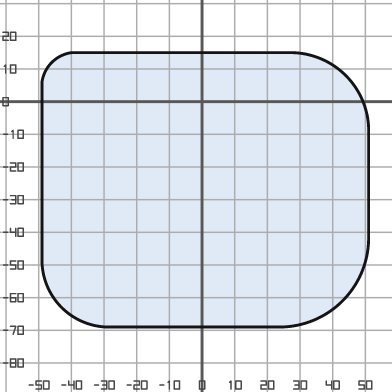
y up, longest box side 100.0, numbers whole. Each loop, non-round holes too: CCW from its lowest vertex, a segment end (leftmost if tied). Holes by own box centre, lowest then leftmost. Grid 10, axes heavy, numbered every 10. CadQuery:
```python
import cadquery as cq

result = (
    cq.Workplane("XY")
    .moveTo(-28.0, -69.0)
    .lineTo(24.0, -69.0)
    .threePointArc((43.0, -61.0), (51.0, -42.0))
    .lineTo(51.0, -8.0)
    .threePointArc((44.0, 8.0), (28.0, 15.0))
    .lineTo(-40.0, 15.0)
    .threePointArc((-46.0, 12.0), (-49.0, 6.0))
    .lineTo(-49.0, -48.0)
    .threePointArc((-43.0, -63.0), (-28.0, -69.0))
    .close()
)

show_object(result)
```